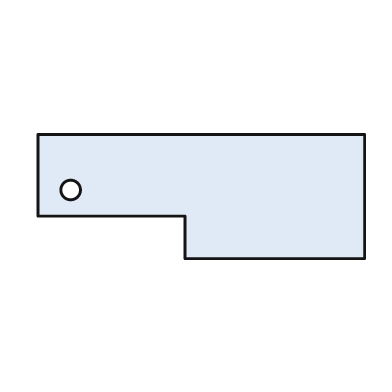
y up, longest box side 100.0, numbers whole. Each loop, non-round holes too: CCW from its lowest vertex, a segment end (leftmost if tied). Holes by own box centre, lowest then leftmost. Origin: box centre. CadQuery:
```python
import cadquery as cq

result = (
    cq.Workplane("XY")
    .moveTo(-5.0, -19.0)
    .lineTo(50.0, -19.0)
    .lineTo(50.0, 19.0)
    .lineTo(-50.0, 19.0)
    .lineTo(-50.0, -6.0)
    .lineTo(-5.0, -6.0)
    .close()
    .moveTo(-40.0, 2.0)
    .circle(3.0)
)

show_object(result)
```